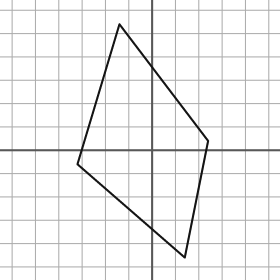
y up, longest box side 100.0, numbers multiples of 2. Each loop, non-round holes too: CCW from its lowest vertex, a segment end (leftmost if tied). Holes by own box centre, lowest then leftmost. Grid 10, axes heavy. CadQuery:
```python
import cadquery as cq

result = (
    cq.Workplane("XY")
    .moveTo(14.0, -46.0)
    .lineTo(24.0, 4.0)
    .lineTo(-14.0, 54.0)
    .lineTo(-32.0, -6.0)
    .close()
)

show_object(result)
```